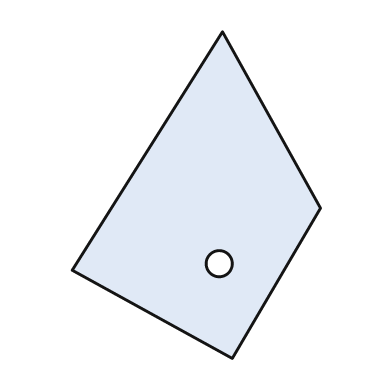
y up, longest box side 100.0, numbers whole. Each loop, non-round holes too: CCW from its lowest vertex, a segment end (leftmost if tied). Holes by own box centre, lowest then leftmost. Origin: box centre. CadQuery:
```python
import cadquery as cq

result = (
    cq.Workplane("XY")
    .moveTo(11.0, -50.0)
    .lineTo(38.0, -4.0)
    .lineTo(8.0, 50.0)
    .lineTo(-38.0, -23.0)
    .close()
    .moveTo(7.0, -21.0)
    .circle(4.0)
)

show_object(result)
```